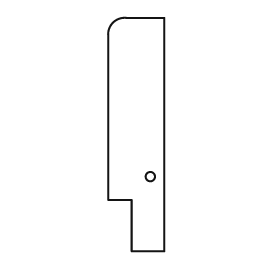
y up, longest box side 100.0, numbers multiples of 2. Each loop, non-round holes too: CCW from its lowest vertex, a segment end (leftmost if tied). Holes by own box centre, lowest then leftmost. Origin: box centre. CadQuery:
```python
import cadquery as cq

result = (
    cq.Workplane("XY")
    .moveTo(-2.0, -50.0)
    .lineTo(12.0, -50.0)
    .lineTo(12.0, 50.0)
    .lineTo(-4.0, 50.0)
    .threePointArc((-10.0, 48.0), (-12.0, 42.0))
    .lineTo(-12.0, -28.0)
    .lineTo(-2.0, -28.0)
    .close()
    .moveTo(6.0, -18.0)
    .circle(2.0)
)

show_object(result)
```